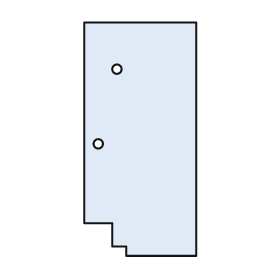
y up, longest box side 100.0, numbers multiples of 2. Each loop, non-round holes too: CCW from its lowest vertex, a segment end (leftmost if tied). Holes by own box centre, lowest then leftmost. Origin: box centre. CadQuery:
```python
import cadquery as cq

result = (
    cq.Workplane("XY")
    .moveTo(-6.0, -50.0)
    .lineTo(24.0, -50.0)
    .lineTo(24.0, 50.0)
    .lineTo(-24.0, 50.0)
    .lineTo(-24.0, -36.0)
    .lineTo(-12.0, -36.0)
    .lineTo(-12.0, -46.0)
    .lineTo(-6.0, -46.0)
    .close()
    .moveTo(-18.0, -2.0)
    .circle(2.0)
    .moveTo(-10.0, 30.0)
    .circle(2.0)
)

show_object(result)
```